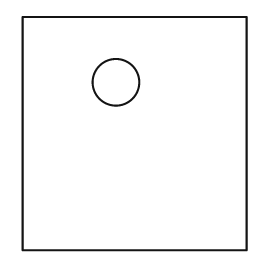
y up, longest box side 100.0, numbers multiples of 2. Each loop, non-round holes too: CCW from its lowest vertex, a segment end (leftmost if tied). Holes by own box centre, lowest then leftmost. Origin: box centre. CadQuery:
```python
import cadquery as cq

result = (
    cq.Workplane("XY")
    .moveTo(-48.0, -50.0)
    .lineTo(48.0, -50.0)
    .lineTo(48.0, 50.0)
    .lineTo(-48.0, 50.0)
    .close()
    .moveTo(-8.0, 22.0)
    .circle(10.0)
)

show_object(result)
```